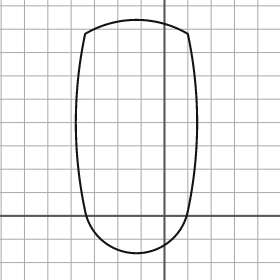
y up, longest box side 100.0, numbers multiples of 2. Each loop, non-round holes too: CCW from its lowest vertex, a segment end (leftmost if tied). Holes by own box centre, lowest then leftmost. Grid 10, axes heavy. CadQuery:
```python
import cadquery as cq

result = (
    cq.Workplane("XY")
    .moveTo(-34.0, 2.0)
    .threePointArc((-12.0, -16.0), (10.0, 2.0))
    .threePointArc((14.0, 40.0), (10.0, 78.0))
    .threePointArc((-12.0, 84.0), (-34.0, 78.0))
    .threePointArc((-38.0, 40.0), (-34.0, 2.0))
    .close()
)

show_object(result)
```